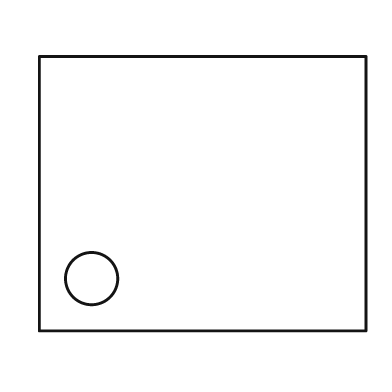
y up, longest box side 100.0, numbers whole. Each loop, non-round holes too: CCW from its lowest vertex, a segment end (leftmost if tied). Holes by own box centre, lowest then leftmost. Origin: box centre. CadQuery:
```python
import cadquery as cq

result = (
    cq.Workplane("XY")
    .moveTo(-50.0, -42.0)
    .lineTo(50.0, -42.0)
    .lineTo(50.0, 42.0)
    .lineTo(-50.0, 42.0)
    .close()
    .moveTo(-34.0, -26.0)
    .circle(8.0)
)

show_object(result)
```